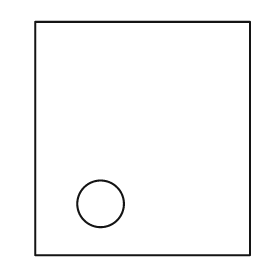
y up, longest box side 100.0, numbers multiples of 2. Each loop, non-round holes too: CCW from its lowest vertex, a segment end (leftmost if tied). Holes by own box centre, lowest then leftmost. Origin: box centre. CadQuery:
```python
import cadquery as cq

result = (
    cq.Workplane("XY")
    .moveTo(-46.0, -50.0)
    .lineTo(46.0, -50.0)
    .lineTo(46.0, 50.0)
    .lineTo(-46.0, 50.0)
    .close()
    .moveTo(-18.0, -28.0)
    .circle(10.0)
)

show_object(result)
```